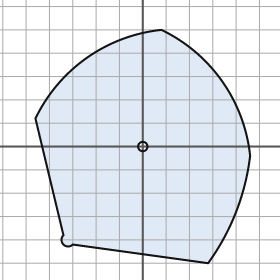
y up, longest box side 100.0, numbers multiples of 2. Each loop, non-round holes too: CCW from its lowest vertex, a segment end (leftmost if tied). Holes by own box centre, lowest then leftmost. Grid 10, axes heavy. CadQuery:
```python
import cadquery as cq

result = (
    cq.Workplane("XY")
    .moveTo(28.0, -50.0)
    .threePointArc((40.0, -28.0), (46.0, -4.0))
    .threePointArc((34.0, 28.0), (8.0, 50.0))
    .threePointArc((-24.0, 38.0), (-46.0, 12.0))
    .lineTo(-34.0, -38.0)
    .threePointArc((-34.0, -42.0), (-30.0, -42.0))
    .close()
    .moveTo(0.0, 0.0)
    .circle(2.0)
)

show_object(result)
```